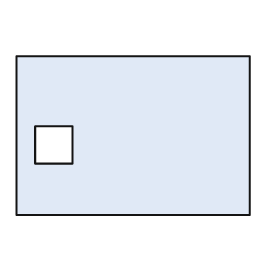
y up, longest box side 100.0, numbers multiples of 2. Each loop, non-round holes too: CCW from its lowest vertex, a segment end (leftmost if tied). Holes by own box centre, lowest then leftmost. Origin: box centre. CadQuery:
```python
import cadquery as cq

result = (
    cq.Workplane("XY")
    .moveTo(-50.0, -34.0)
    .lineTo(50.0, -34.0)
    .lineTo(50.0, 34.0)
    .lineTo(-50.0, 34.0)
    .close()
    .moveTo(-42.0, -12.0)
    .lineTo(-26.0, -12.0)
    .lineTo(-26.0, 4.0)
    .lineTo(-42.0, 4.0)
    .close()
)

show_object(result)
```